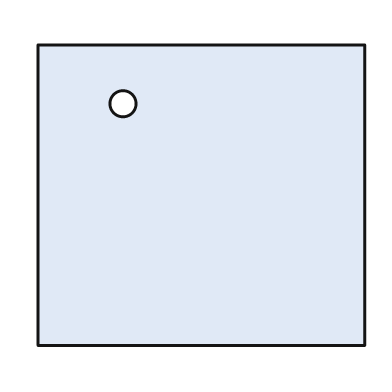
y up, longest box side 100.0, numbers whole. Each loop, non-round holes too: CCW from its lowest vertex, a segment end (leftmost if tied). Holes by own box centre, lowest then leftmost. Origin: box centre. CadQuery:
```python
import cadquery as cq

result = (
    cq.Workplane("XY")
    .moveTo(-50.0, -46.0)
    .lineTo(50.0, -46.0)
    .lineTo(50.0, 46.0)
    .lineTo(-50.0, 46.0)
    .close()
    .moveTo(-24.0, 28.0)
    .circle(4.0)
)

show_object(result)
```